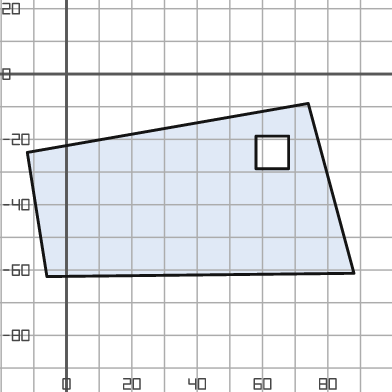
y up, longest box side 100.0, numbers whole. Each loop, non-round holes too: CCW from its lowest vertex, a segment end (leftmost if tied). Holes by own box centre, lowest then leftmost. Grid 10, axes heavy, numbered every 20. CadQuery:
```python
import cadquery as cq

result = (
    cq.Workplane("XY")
    .moveTo(-6.0, -62.0)
    .lineTo(88.0, -61.0)
    .lineTo(74.0, -9.0)
    .lineTo(-12.0, -24.0)
    .close()
    .moveTo(58.0, -29.0)
    .lineTo(68.0, -29.0)
    .lineTo(68.0, -19.0)
    .lineTo(58.0, -19.0)
    .close()
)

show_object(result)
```